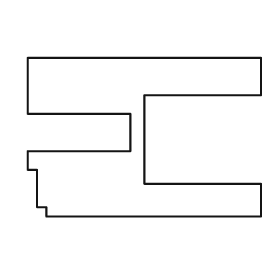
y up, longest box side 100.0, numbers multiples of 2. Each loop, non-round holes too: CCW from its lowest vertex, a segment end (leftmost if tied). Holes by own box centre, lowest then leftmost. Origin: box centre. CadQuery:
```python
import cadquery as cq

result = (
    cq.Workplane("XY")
    .moveTo(-42.0, -34.0)
    .lineTo(50.0, -34.0)
    .lineTo(50.0, -20.0)
    .lineTo(0.0, -20.0)
    .lineTo(0.0, 18.0)
    .lineTo(50.0, 18.0)
    .lineTo(50.0, 34.0)
    .lineTo(-50.0, 34.0)
    .lineTo(-50.0, 10.0)
    .lineTo(-6.0, 10.0)
    .lineTo(-6.0, -6.0)
    .lineTo(-50.0, -6.0)
    .lineTo(-50.0, -14.0)
    .lineTo(-46.0, -14.0)
    .lineTo(-46.0, -30.0)
    .lineTo(-42.0, -30.0)
    .close()
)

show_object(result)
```